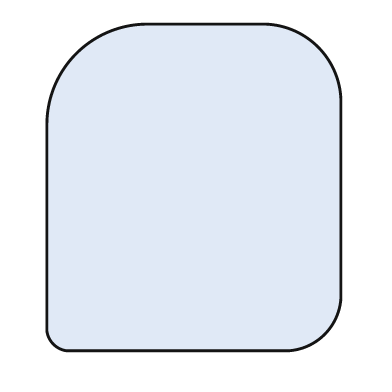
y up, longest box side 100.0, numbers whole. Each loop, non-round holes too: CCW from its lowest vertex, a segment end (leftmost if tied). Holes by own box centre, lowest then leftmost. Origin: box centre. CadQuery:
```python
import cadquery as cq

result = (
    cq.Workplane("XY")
    .moveTo(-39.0, -50.0)
    .lineTo(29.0, -50.0)
    .threePointArc((40.0, -45.0), (45.0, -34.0))
    .lineTo(45.0, 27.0)
    .threePointArc((38.0, 43.0), (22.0, 50.0))
    .lineTo(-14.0, 50.0)
    .threePointArc((-36.0, 41.0), (-45.0, 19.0))
    .lineTo(-45.0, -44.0)
    .threePointArc((-43.0, -48.0), (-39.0, -50.0))
    .close()
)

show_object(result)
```